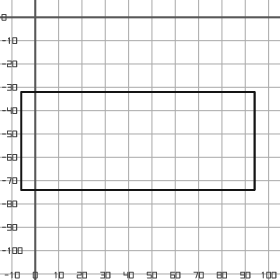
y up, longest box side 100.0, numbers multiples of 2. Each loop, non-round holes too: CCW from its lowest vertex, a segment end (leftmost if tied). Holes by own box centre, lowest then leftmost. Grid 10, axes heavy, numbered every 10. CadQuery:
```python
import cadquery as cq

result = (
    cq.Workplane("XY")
    .moveTo(-6.0, -74.0)
    .lineTo(94.0, -74.0)
    .lineTo(94.0, -32.0)
    .lineTo(-6.0, -32.0)
    .close()
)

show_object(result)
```